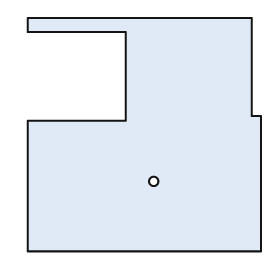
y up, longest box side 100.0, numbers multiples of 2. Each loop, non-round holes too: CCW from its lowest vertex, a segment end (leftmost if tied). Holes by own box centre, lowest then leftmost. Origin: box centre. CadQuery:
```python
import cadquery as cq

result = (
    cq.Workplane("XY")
    .moveTo(-50.0, -50.0)
    .lineTo(50.0, -50.0)
    .lineTo(50.0, 8.0)
    .lineTo(46.0, 8.0)
    .lineTo(46.0, 50.0)
    .lineTo(-50.0, 50.0)
    .lineTo(-50.0, 44.0)
    .lineTo(-8.0, 44.0)
    .lineTo(-8.0, 6.0)
    .lineTo(-50.0, 6.0)
    .close()
    .moveTo(4.0, -20.0)
    .circle(2.0)
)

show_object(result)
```